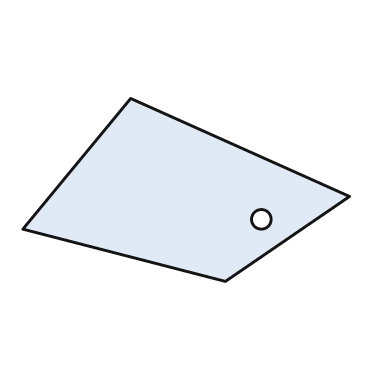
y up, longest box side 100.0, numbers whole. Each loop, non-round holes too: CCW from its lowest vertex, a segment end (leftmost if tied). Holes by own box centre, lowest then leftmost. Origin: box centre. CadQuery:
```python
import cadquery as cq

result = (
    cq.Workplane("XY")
    .moveTo(12.0, -28.0)
    .lineTo(50.0, -2.0)
    .lineTo(-17.0, 28.0)
    .lineTo(-50.0, -12.0)
    .close()
    .moveTo(23.0, -9.0)
    .circle(3.0)
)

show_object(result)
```